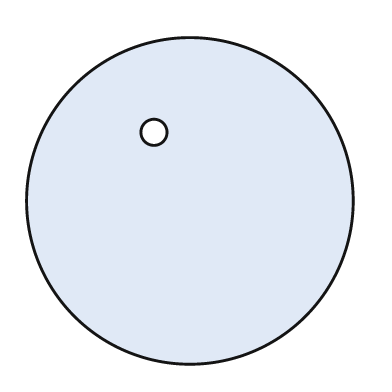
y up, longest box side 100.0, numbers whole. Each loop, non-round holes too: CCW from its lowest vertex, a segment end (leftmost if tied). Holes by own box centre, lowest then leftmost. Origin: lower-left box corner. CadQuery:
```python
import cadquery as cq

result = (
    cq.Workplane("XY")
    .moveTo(50.0, 50.0)
    .circle(50.0)
    .moveTo(39.0, 71.0)
    .circle(4.0)
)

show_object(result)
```